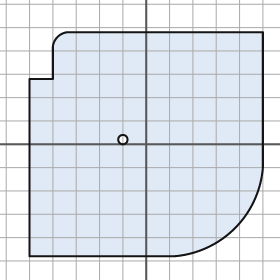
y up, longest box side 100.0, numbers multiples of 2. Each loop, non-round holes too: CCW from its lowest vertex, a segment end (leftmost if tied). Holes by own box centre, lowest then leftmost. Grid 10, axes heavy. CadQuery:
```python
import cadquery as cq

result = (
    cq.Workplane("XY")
    .moveTo(-50.0, -48.0)
    .lineTo(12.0, -48.0)
    .threePointArc((38.0, -36.0), (50.0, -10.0))
    .lineTo(50.0, 48.0)
    .lineTo(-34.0, 48.0)
    .threePointArc((-38.0, 46.0), (-40.0, 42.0))
    .lineTo(-40.0, 28.0)
    .lineTo(-50.0, 28.0)
    .close()
    .moveTo(-10.0, 2.0)
    .circle(2.0)
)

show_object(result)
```